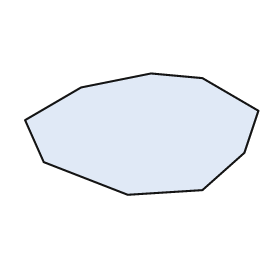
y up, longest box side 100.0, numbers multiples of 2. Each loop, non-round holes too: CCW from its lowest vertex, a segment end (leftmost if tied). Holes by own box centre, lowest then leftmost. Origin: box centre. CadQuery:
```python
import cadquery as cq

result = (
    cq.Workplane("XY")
    .moveTo(-6.0, -26.0)
    .lineTo(26.0, -24.0)
    .lineTo(44.0, -8.0)
    .lineTo(50.0, 10.0)
    .lineTo(26.0, 24.0)
    .lineTo(4.0, 26.0)
    .lineTo(-26.0, 20.0)
    .lineTo(-50.0, 6.0)
    .lineTo(-42.0, -12.0)
    .close()
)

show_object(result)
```